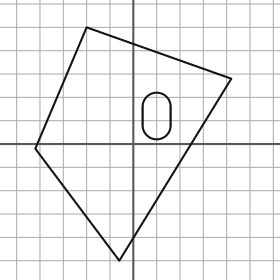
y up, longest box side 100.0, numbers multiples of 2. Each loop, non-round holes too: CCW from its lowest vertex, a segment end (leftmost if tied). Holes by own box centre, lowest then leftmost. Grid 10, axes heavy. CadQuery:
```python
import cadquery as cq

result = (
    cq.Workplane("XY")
    .moveTo(-6.0, -50.0)
    .lineTo(42.0, 28.0)
    .lineTo(-20.0, 50.0)
    .lineTo(-42.0, -2.0)
    .close()
    .moveTo(4.0, 8.0)
    .threePointArc((10.0, 2.0), (16.0, 8.0))
    .lineTo(16.0, 16.0)
    .threePointArc((10.0, 22.0), (4.0, 16.0))
    .close()
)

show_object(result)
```